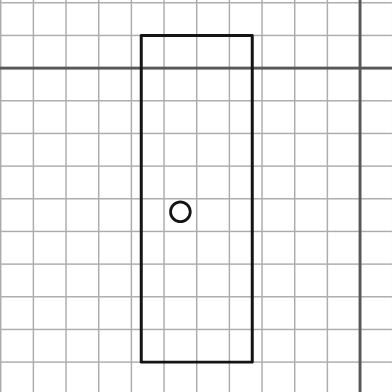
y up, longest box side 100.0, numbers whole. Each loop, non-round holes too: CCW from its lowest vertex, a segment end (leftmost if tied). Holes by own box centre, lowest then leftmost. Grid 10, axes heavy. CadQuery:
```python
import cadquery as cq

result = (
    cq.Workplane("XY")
    .moveTo(-67.0, -90.0)
    .lineTo(-33.0, -90.0)
    .lineTo(-33.0, 10.0)
    .lineTo(-67.0, 10.0)
    .close()
    .moveTo(-55.0, -44.0)
    .circle(3.0)
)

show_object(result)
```